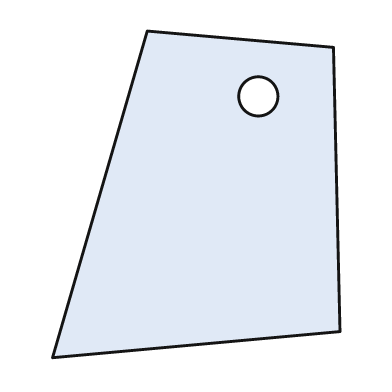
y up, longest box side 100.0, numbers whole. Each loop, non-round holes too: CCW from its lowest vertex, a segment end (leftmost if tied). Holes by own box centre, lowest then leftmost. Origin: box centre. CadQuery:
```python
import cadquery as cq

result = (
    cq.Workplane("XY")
    .moveTo(-44.0, -50.0)
    .lineTo(44.0, -42.0)
    .lineTo(42.0, 45.0)
    .lineTo(-15.0, 50.0)
    .close()
    .moveTo(19.0, 30.0)
    .circle(6.0)
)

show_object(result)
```